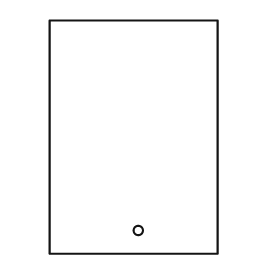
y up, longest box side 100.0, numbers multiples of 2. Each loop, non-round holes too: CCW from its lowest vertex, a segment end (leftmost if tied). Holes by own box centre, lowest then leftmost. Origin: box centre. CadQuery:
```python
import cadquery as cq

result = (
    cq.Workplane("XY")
    .moveTo(-36.0, -50.0)
    .lineTo(36.0, -50.0)
    .lineTo(36.0, 50.0)
    .lineTo(-36.0, 50.0)
    .close()
    .moveTo(2.0, -40.0)
    .circle(2.0)
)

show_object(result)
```